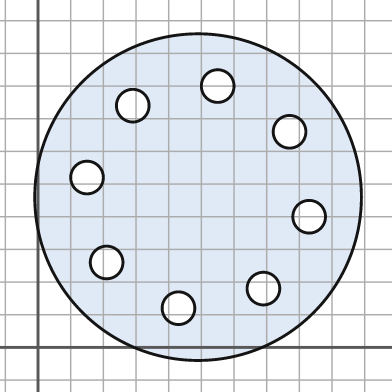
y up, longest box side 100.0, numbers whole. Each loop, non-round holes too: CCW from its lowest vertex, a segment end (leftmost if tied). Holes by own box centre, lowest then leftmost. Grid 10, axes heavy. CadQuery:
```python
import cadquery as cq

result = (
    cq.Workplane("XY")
    .moveTo(49.0, 46.0)
    .circle(50.0)
    .moveTo(43.0, 12.0)
    .circle(5.0)
    .moveTo(69.0, 18.0)
    .circle(5.0)
    .moveTo(21.0, 26.0)
    .circle(5.0)
    .moveTo(83.0, 40.0)
    .circle(5.0)
    .moveTo(15.0, 52.0)
    .circle(5.0)
    .moveTo(77.0, 66.0)
    .circle(5.0)
    .moveTo(29.0, 74.0)
    .circle(5.0)
    .moveTo(55.0, 80.0)
    .circle(5.0)
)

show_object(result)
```